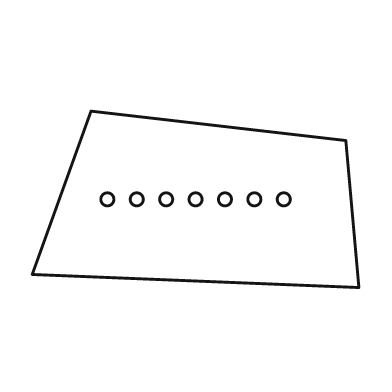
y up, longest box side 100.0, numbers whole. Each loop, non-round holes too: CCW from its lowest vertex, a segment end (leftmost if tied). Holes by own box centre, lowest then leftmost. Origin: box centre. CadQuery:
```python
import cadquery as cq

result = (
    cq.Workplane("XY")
    .moveTo(50.0, -27.0)
    .lineTo(46.0, 18.0)
    .lineTo(-32.0, 27.0)
    .lineTo(-50.0, -23.0)
    .close()
    .moveTo(-27.0, 0.0)
    .circle(2.0)
    .moveTo(-18.0, 0.0)
    .circle(2.0)
    .moveTo(-9.0, 0.0)
    .circle(2.0)
    .moveTo(0.0, 0.0)
    .circle(2.0)
    .moveTo(9.0, 0.0)
    .circle(2.0)
    .moveTo(18.0, 0.0)
    .circle(2.0)
    .moveTo(27.0, 0.0)
    .circle(2.0)
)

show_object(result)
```